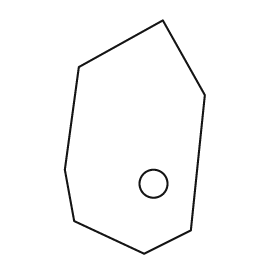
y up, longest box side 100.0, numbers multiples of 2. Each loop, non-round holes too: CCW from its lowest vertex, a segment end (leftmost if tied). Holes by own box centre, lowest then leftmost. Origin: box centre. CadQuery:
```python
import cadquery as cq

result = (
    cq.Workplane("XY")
    .moveTo(4.0, -50.0)
    .lineTo(24.0, -40.0)
    .lineTo(30.0, 18.0)
    .lineTo(12.0, 50.0)
    .lineTo(-24.0, 30.0)
    .lineTo(-30.0, -14.0)
    .lineTo(-26.0, -36.0)
    .close()
    .moveTo(8.0, -20.0)
    .circle(6.0)
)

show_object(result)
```